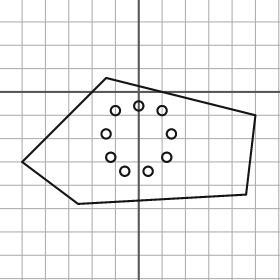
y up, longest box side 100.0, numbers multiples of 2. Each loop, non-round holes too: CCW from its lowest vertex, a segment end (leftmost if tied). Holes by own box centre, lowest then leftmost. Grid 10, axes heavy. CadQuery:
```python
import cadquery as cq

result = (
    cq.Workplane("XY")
    .moveTo(-26.0, -48.0)
    .lineTo(46.0, -44.0)
    .lineTo(50.0, -10.0)
    .lineTo(-14.0, 6.0)
    .lineTo(-50.0, -30.0)
    .close()
    .moveTo(-6.0, -34.0)
    .circle(2.0)
    .moveTo(4.0, -34.0)
    .circle(2.0)
    .moveTo(-12.0, -28.0)
    .circle(2.0)
    .moveTo(12.0, -28.0)
    .circle(2.0)
    .moveTo(-14.0, -18.0)
    .circle(2.0)
    .moveTo(14.0, -18.0)
    .circle(2.0)
    .moveTo(-10.0, -8.0)
    .circle(2.0)
    .moveTo(10.0, -8.0)
    .circle(2.0)
    .moveTo(0.0, -6.0)
    .circle(2.0)
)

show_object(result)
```